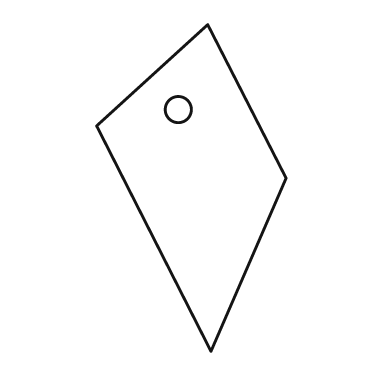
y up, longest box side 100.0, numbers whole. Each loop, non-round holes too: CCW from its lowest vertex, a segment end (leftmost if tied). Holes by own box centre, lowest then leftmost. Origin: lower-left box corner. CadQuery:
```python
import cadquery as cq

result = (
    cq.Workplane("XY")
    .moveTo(35.0, 0.0)
    .lineTo(58.0, 53.0)
    .lineTo(34.0, 100.0)
    .lineTo(0.0, 69.0)
    .close()
    .moveTo(25.0, 74.0)
    .circle(4.0)
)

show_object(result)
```